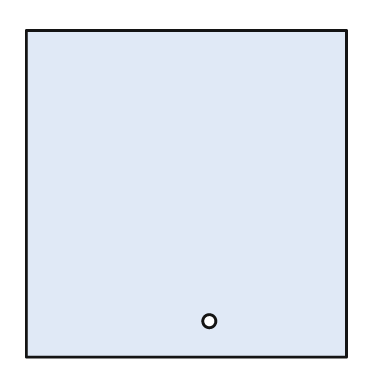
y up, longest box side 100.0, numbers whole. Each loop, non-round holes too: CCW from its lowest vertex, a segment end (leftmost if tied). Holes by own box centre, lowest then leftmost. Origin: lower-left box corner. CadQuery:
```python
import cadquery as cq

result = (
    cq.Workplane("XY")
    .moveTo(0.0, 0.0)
    .lineTo(98.0, 0.0)
    .lineTo(98.0, 100.0)
    .lineTo(0.0, 100.0)
    .close()
    .moveTo(56.0, 11.0)
    .circle(2.0)
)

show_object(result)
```